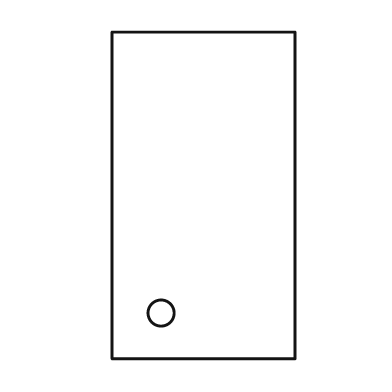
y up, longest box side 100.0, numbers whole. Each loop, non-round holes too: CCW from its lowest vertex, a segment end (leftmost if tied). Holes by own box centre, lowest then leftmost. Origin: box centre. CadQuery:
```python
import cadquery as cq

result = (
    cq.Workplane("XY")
    .moveTo(-28.0, -50.0)
    .lineTo(28.0, -50.0)
    .lineTo(28.0, 50.0)
    .lineTo(-28.0, 50.0)
    .close()
    .moveTo(-13.0, -36.0)
    .circle(4.0)
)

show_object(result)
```